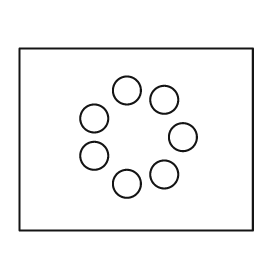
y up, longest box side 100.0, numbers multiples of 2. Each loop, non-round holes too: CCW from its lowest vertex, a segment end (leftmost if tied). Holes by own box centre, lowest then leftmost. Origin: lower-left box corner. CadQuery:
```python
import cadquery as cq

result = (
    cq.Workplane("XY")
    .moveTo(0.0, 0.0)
    .lineTo(100.0, 0.0)
    .lineTo(100.0, 78.0)
    .lineTo(0.0, 78.0)
    .close()
    .moveTo(46.0, 20.0)
    .circle(6.0)
    .moveTo(62.0, 24.0)
    .circle(6.0)
    .moveTo(32.0, 32.0)
    .circle(6.0)
    .moveTo(70.0, 40.0)
    .circle(6.0)
    .moveTo(32.0, 48.0)
    .circle(6.0)
    .moveTo(62.0, 56.0)
    .circle(6.0)
    .moveTo(46.0, 60.0)
    .circle(6.0)
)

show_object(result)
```